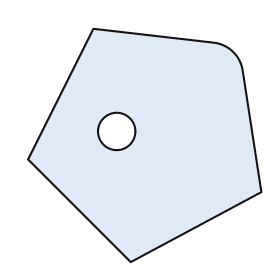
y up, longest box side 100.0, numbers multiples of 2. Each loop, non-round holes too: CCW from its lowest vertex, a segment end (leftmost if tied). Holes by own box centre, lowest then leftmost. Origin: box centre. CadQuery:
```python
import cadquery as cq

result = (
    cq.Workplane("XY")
    .moveTo(-6.0, -50.0)
    .lineTo(50.0, -20.0)
    .lineTo(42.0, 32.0)
    .threePointArc((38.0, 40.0), (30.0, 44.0))
    .lineTo(-22.0, 50.0)
    .lineTo(-50.0, -6.0)
    .close()
    .moveTo(-12.0, 6.0)
    .circle(8.0)
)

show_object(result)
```